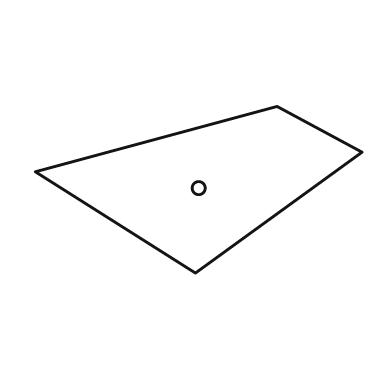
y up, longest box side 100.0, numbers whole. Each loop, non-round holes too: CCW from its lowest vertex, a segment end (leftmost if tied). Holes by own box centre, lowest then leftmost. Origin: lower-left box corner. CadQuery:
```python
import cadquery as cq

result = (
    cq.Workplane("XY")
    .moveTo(49.0, 0.0)
    .lineTo(100.0, 37.0)
    .lineTo(74.0, 51.0)
    .lineTo(0.0, 31.0)
    .close()
    .moveTo(50.0, 26.0)
    .circle(2.0)
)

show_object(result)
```